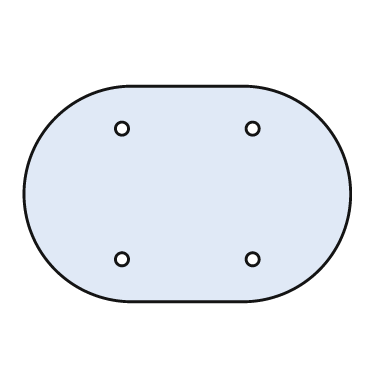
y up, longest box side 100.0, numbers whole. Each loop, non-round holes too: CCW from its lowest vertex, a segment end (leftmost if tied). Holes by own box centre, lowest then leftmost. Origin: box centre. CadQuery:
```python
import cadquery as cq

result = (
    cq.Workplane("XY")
    .moveTo(-17.0, -33.0)
    .lineTo(17.0, -33.0)
    .threePointArc((50.0, 0.0), (17.0, 33.0))
    .lineTo(-17.0, 33.0)
    .threePointArc((-50.0, 0.0), (-17.0, -33.0))
    .close()
    .moveTo(-20.0, -20.0)
    .circle(2.0)
    .moveTo(20.0, -20.0)
    .circle(2.0)
    .moveTo(-20.0, 20.0)
    .circle(2.0)
    .moveTo(20.0, 20.0)
    .circle(2.0)
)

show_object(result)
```